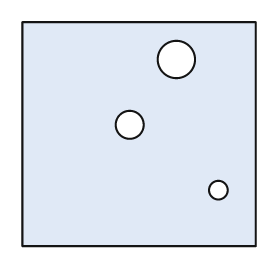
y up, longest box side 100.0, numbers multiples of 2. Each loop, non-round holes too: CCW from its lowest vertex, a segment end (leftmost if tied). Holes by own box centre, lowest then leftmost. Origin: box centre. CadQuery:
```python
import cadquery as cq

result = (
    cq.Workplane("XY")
    .moveTo(-50.0, -48.0)
    .lineTo(50.0, -48.0)
    .lineTo(50.0, 48.0)
    .lineTo(-50.0, 48.0)
    .close()
    .moveTo(34.0, -24.0)
    .circle(4.0)
    .moveTo(-4.0, 4.0)
    .circle(6.0)
    .moveTo(16.0, 32.0)
    .circle(8.0)
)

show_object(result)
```